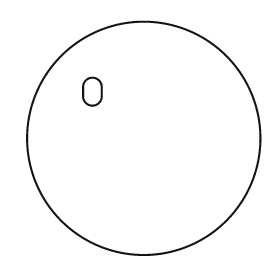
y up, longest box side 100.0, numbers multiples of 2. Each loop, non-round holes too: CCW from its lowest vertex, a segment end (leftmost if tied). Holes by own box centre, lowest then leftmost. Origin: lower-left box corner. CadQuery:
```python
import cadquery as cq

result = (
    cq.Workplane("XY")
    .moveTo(50.0, 50.0)
    .circle(50.0)
    .moveTo(24.0, 68.0)
    .threePointArc((28.0, 64.0), (32.0, 68.0))
    .lineTo(32.0, 72.0)
    .threePointArc((28.0, 76.0), (24.0, 72.0))
    .close()
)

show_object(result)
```